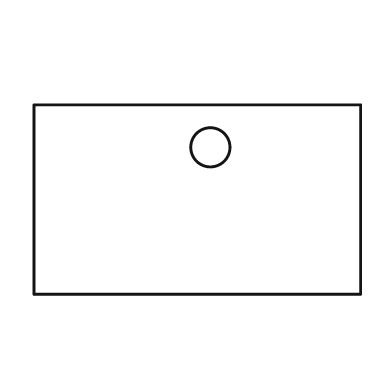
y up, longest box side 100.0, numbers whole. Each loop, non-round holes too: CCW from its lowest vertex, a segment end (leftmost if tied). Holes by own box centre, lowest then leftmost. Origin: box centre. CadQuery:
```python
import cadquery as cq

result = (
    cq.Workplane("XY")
    .moveTo(-50.0, -29.0)
    .lineTo(50.0, -29.0)
    .lineTo(50.0, 29.0)
    .lineTo(-50.0, 29.0)
    .close()
    .moveTo(4.0, 16.0)
    .circle(6.0)
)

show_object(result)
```